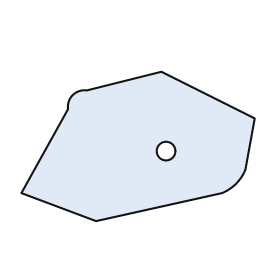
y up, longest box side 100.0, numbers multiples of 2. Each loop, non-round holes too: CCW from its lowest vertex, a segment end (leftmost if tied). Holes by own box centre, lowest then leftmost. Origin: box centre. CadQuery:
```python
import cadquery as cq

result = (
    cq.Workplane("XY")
    .moveTo(-18.0, -32.0)
    .lineTo(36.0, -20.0)
    .threePointArc((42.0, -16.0), (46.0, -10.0))
    .lineTo(50.0, 12.0)
    .lineTo(10.0, 32.0)
    .lineTo(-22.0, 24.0)
    .threePointArc((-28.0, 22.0), (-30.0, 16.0))
    .lineTo(-50.0, -20.0)
    .close()
    .moveTo(12.0, -2.0)
    .circle(4.0)
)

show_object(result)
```